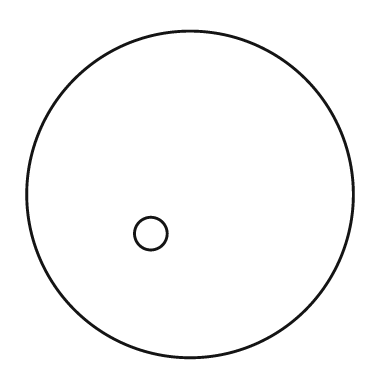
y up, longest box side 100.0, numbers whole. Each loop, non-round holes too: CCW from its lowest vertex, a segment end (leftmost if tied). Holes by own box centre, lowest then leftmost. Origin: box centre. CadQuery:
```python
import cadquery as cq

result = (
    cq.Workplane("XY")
    .moveTo(0.0, 0.0)
    .circle(50.0)
    .moveTo(-12.0, -12.0)
    .circle(5.0)
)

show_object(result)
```